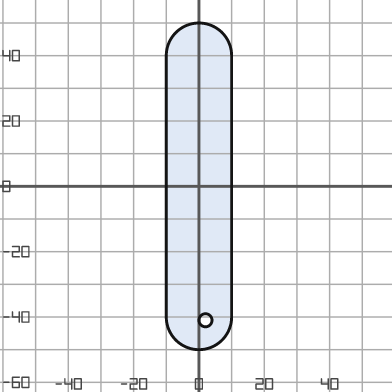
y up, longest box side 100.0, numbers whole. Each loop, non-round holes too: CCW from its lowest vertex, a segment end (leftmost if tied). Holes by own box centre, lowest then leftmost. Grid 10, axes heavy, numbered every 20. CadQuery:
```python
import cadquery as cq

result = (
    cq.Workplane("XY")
    .moveTo(-10.0, -40.0)
    .threePointArc((0.0, -50.0), (10.0, -40.0))
    .lineTo(10.0, 40.0)
    .threePointArc((0.0, 50.0), (-10.0, 40.0))
    .close()
    .moveTo(2.0, -41.0)
    .circle(2.0)
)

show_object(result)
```